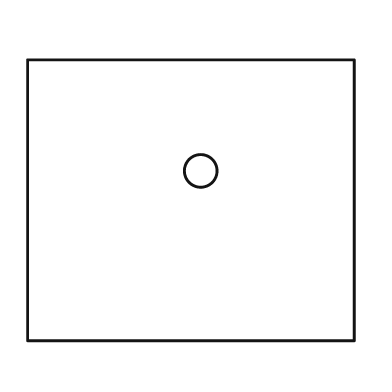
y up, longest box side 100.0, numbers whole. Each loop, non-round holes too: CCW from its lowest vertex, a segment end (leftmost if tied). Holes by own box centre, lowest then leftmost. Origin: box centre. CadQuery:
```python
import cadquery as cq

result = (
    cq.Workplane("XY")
    .moveTo(-50.0, -43.0)
    .lineTo(50.0, -43.0)
    .lineTo(50.0, 43.0)
    .lineTo(-50.0, 43.0)
    .close()
    .moveTo(3.0, 9.0)
    .circle(5.0)
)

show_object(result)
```